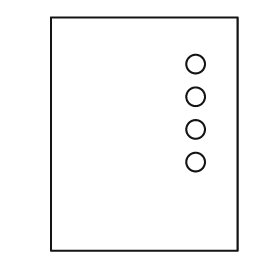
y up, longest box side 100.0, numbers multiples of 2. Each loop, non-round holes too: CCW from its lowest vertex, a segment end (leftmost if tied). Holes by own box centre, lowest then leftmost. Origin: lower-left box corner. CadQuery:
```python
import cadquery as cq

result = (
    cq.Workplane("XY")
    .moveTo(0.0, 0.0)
    .lineTo(80.0, 0.0)
    .lineTo(80.0, 100.0)
    .lineTo(0.0, 100.0)
    .close()
    .moveTo(62.0, 38.0)
    .circle(4.0)
    .moveTo(62.0, 52.0)
    .circle(4.0)
    .moveTo(62.0, 66.0)
    .circle(4.0)
    .moveTo(62.0, 80.0)
    .circle(4.0)
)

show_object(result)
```